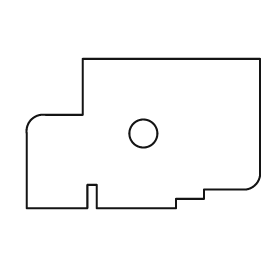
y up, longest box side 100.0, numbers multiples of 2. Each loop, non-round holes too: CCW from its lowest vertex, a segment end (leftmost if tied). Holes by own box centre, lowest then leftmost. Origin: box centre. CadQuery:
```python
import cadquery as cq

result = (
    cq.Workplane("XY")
    .moveTo(-50.0, -32.0)
    .lineTo(-24.0, -32.0)
    .lineTo(-24.0, -22.0)
    .lineTo(-20.0, -22.0)
    .lineTo(-20.0, -32.0)
    .lineTo(14.0, -32.0)
    .lineTo(14.0, -28.0)
    .lineTo(26.0, -28.0)
    .lineTo(26.0, -24.0)
    .lineTo(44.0, -24.0)
    .threePointArc((48.0, -22.0), (50.0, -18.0))
    .lineTo(50.0, 32.0)
    .lineTo(-26.0, 32.0)
    .lineTo(-26.0, 8.0)
    .lineTo(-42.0, 8.0)
    .threePointArc((-48.0, 6.0), (-50.0, 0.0))
    .close()
    .moveTo(0.0, 0.0)
    .circle(6.0)
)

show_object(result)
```